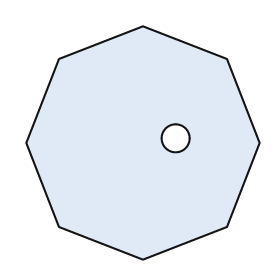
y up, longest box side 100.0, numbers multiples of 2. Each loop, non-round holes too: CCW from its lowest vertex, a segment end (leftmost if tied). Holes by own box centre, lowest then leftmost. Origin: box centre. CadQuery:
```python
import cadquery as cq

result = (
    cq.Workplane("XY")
    .moveTo(0.0, -50.0)
    .lineTo(36.0, -36.0)
    .lineTo(50.0, 0.0)
    .lineTo(36.0, 36.0)
    .lineTo(0.0, 50.0)
    .lineTo(-36.0, 36.0)
    .lineTo(-50.0, 0.0)
    .lineTo(-36.0, -36.0)
    .close()
    .moveTo(14.0, 2.0)
    .circle(6.0)
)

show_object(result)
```